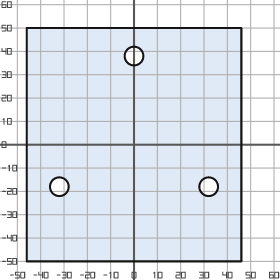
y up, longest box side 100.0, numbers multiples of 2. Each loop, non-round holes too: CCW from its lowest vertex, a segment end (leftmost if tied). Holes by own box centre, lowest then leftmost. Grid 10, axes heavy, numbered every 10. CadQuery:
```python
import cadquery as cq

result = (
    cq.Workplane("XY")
    .moveTo(-46.0, -50.0)
    .lineTo(46.0, -50.0)
    .lineTo(46.0, 50.0)
    .lineTo(-46.0, 50.0)
    .close()
    .moveTo(-32.0, -18.0)
    .circle(4.0)
    .moveTo(32.0, -18.0)
    .circle(4.0)
    .moveTo(0.0, 38.0)
    .circle(4.0)
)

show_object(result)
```